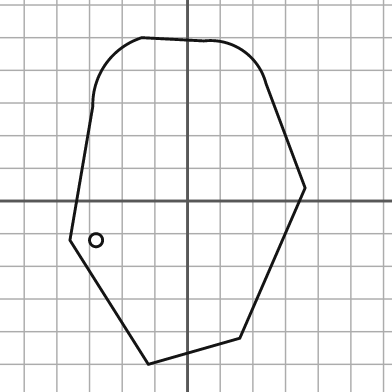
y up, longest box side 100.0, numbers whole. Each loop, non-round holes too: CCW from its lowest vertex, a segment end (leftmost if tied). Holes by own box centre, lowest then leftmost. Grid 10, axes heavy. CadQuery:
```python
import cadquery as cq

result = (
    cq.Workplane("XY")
    .moveTo(-12.0, -50.0)
    .lineTo(16.0, -42.0)
    .lineTo(36.0, 4.0)
    .lineTo(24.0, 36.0)
    .threePointArc((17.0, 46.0), (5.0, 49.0))
    .lineTo(-14.0, 50.0)
    .threePointArc((-25.0, 42.0), (-29.0, 29.0))
    .lineTo(-36.0, -12.0)
    .close()
    .moveTo(-28.0, -12.0)
    .circle(2.0)
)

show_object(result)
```